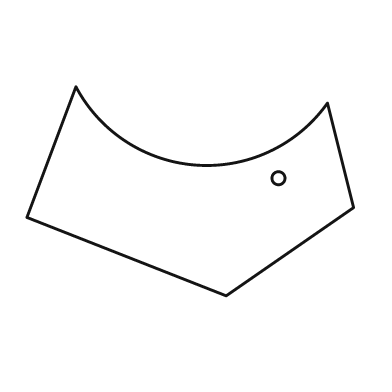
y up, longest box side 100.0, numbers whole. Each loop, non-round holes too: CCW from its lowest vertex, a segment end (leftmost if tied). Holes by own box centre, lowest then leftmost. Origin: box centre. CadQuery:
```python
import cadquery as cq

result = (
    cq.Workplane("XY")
    .moveTo(11.0, -32.0)
    .lineTo(50.0, -5.0)
    .lineTo(42.0, 27.0)
    .threePointArc((2.0, 8.0), (-35.0, 32.0))
    .lineTo(-50.0, -8.0)
    .close()
    .moveTo(27.0, 4.0)
    .circle(2.0)
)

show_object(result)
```